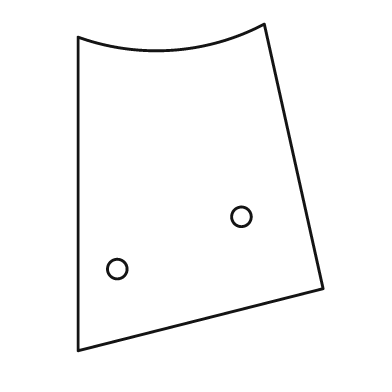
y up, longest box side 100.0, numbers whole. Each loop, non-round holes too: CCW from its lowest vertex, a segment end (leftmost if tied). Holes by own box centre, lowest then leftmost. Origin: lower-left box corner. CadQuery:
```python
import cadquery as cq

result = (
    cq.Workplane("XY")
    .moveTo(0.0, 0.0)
    .lineTo(75.0, 19.0)
    .lineTo(57.0, 100.0)
    .threePointArc((29.0, 92.0), (0.0, 96.0))
    .close()
    .moveTo(12.0, 25.0)
    .circle(3.0)
    .moveTo(50.0, 41.0)
    .circle(3.0)
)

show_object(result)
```